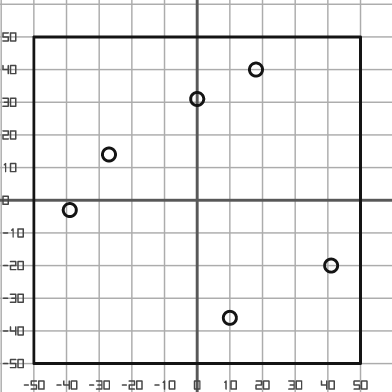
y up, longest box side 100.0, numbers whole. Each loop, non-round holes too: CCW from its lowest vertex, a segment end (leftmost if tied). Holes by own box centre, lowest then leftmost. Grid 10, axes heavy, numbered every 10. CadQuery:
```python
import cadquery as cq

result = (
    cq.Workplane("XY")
    .moveTo(-50.0, -50.0)
    .lineTo(50.0, -50.0)
    .lineTo(50.0, 50.0)
    .lineTo(-50.0, 50.0)
    .close()
    .moveTo(10.0, -36.0)
    .circle(2.0)
    .moveTo(41.0, -20.0)
    .circle(2.0)
    .moveTo(-39.0, -3.0)
    .circle(2.0)
    .moveTo(-27.0, 14.0)
    .circle(2.0)
    .moveTo(0.0, 31.0)
    .circle(2.0)
    .moveTo(18.0, 40.0)
    .circle(2.0)
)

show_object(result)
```